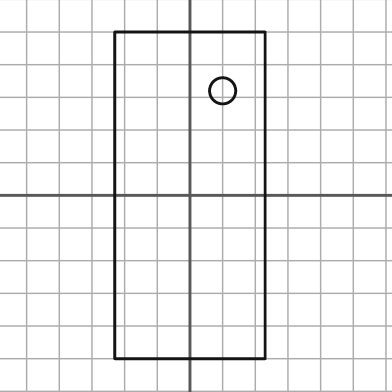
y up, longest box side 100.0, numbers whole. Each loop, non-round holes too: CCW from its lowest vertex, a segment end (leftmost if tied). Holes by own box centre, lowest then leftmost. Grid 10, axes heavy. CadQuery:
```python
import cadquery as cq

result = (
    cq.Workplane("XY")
    .moveTo(-23.0, -50.0)
    .lineTo(23.0, -50.0)
    .lineTo(23.0, 50.0)
    .lineTo(-23.0, 50.0)
    .close()
    .moveTo(10.0, 32.0)
    .circle(4.0)
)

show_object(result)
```